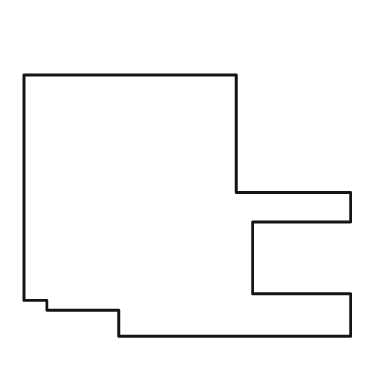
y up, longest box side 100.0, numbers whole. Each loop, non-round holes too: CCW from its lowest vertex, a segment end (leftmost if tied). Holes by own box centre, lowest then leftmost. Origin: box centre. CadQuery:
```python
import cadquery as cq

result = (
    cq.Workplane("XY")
    .moveTo(-21.0, -40.0)
    .lineTo(50.0, -40.0)
    .lineTo(50.0, -27.0)
    .lineTo(20.0, -27.0)
    .lineTo(20.0, -5.0)
    .lineTo(50.0, -5.0)
    .lineTo(50.0, 4.0)
    .lineTo(15.0, 4.0)
    .lineTo(15.0, 40.0)
    .lineTo(-50.0, 40.0)
    .lineTo(-50.0, -29.0)
    .lineTo(-43.0, -29.0)
    .lineTo(-43.0, -32.0)
    .lineTo(-21.0, -32.0)
    .close()
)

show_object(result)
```